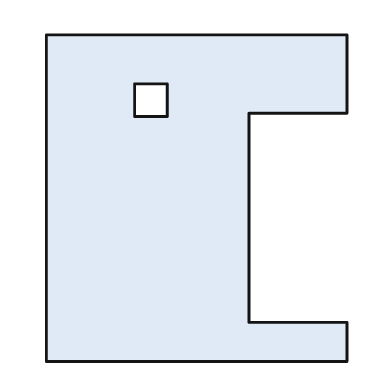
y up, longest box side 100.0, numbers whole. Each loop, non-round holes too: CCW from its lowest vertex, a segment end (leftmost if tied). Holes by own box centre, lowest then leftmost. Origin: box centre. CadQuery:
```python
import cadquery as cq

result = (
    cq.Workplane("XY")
    .moveTo(-46.0, -50.0)
    .lineTo(46.0, -50.0)
    .lineTo(46.0, -38.0)
    .lineTo(16.0, -38.0)
    .lineTo(16.0, 26.0)
    .lineTo(46.0, 26.0)
    .lineTo(46.0, 50.0)
    .lineTo(-46.0, 50.0)
    .close()
    .moveTo(-19.0, 25.0)
    .lineTo(-9.0, 25.0)
    .lineTo(-9.0, 35.0)
    .lineTo(-19.0, 35.0)
    .close()
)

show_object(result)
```